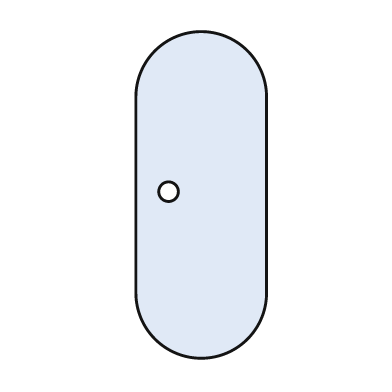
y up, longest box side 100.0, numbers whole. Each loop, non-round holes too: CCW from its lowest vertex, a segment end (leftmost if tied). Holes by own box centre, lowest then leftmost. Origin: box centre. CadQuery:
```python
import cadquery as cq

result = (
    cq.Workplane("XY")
    .moveTo(-20.0, -30.0)
    .threePointArc((0.0, -50.0), (20.0, -30.0))
    .lineTo(20.0, 30.0)
    .threePointArc((0.0, 50.0), (-20.0, 30.0))
    .close()
    .moveTo(-10.0, 1.0)
    .circle(3.0)
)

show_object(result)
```